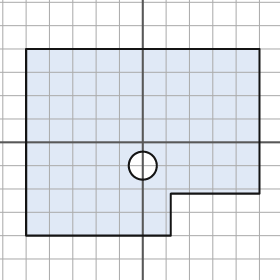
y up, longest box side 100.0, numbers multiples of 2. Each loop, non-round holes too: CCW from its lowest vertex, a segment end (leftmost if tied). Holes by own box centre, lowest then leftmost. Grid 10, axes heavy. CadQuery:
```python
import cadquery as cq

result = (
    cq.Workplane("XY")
    .moveTo(-50.0, -40.0)
    .lineTo(12.0, -40.0)
    .lineTo(12.0, -22.0)
    .lineTo(50.0, -22.0)
    .lineTo(50.0, 40.0)
    .lineTo(-50.0, 40.0)
    .close()
    .moveTo(0.0, -10.0)
    .circle(6.0)
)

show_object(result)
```